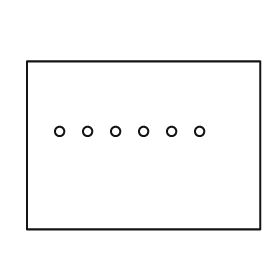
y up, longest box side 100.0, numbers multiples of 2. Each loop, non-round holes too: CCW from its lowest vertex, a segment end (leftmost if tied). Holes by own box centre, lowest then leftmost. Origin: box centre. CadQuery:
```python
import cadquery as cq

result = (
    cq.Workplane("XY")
    .moveTo(-50.0, -36.0)
    .lineTo(50.0, -36.0)
    .lineTo(50.0, 36.0)
    .lineTo(-50.0, 36.0)
    .close()
    .moveTo(-36.0, 6.0)
    .circle(2.0)
    .moveTo(-24.0, 6.0)
    .circle(2.0)
    .moveTo(-12.0, 6.0)
    .circle(2.0)
    .moveTo(0.0, 6.0)
    .circle(2.0)
    .moveTo(12.0, 6.0)
    .circle(2.0)
    .moveTo(24.0, 6.0)
    .circle(2.0)
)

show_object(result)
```